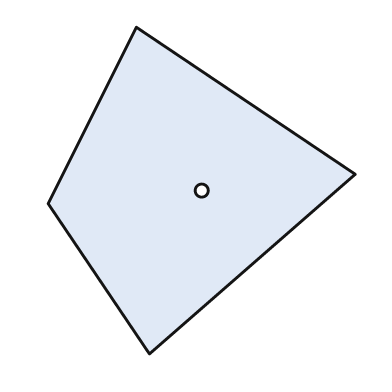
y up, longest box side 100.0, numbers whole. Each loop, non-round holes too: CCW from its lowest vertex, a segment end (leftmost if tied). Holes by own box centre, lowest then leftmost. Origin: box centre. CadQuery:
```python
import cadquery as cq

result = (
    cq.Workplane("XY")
    .moveTo(-16.0, -50.0)
    .lineTo(47.0, 5.0)
    .lineTo(-20.0, 50.0)
    .lineTo(-47.0, -4.0)
    .close()
    .moveTo(0.0, 0.0)
    .circle(2.0)
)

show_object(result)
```